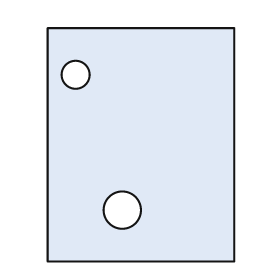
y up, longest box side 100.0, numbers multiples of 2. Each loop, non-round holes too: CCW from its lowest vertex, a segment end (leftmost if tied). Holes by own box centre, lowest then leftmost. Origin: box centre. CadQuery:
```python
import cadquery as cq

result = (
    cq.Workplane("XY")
    .moveTo(-40.0, -50.0)
    .lineTo(40.0, -50.0)
    .lineTo(40.0, 50.0)
    .lineTo(-40.0, 50.0)
    .close()
    .moveTo(-8.0, -28.0)
    .circle(8.0)
    .moveTo(-28.0, 30.0)
    .circle(6.0)
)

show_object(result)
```